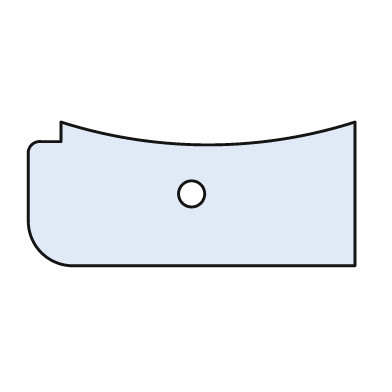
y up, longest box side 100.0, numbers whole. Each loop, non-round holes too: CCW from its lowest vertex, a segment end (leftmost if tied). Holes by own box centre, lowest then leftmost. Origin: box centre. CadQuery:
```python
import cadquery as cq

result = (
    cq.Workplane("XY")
    .moveTo(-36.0, -22.0)
    .lineTo(50.0, -22.0)
    .lineTo(50.0, 22.0)
    .threePointArc((5.0, 15.0), (-40.0, 22.0))
    .lineTo(-40.0, 16.0)
    .lineTo(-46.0, 16.0)
    .threePointArc((-49.0, 15.0), (-50.0, 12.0))
    .lineTo(-50.0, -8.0)
    .threePointArc((-46.0, -18.0), (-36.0, -22.0))
    .close()
    .moveTo(0.0, 0.0)
    .circle(4.0)
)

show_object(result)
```